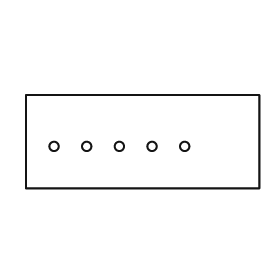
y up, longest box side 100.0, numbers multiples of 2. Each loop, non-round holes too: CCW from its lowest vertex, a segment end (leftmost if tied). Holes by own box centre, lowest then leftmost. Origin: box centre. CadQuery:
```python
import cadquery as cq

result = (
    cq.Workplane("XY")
    .moveTo(-50.0, -20.0)
    .lineTo(50.0, -20.0)
    .lineTo(50.0, 20.0)
    .lineTo(-50.0, 20.0)
    .close()
    .moveTo(-38.0, -2.0)
    .circle(2.0)
    .moveTo(-24.0, -2.0)
    .circle(2.0)
    .moveTo(-10.0, -2.0)
    .circle(2.0)
    .moveTo(4.0, -2.0)
    .circle(2.0)
    .moveTo(18.0, -2.0)
    .circle(2.0)
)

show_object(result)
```